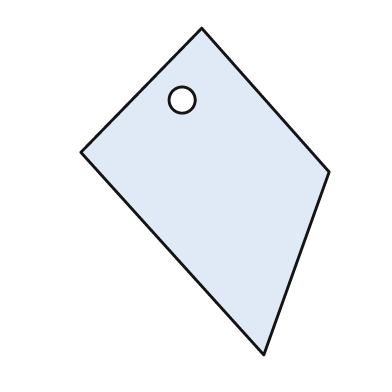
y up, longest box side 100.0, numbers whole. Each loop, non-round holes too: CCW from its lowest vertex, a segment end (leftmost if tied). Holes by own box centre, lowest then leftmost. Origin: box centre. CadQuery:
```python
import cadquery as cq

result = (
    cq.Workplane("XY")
    .moveTo(18.0, -50.0)
    .lineTo(38.0, 6.0)
    .lineTo(-1.0, 50.0)
    .lineTo(-38.0, 12.0)
    .close()
    .moveTo(-7.0, 28.0)
    .circle(4.0)
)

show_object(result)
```